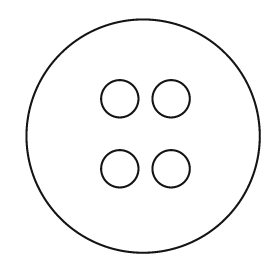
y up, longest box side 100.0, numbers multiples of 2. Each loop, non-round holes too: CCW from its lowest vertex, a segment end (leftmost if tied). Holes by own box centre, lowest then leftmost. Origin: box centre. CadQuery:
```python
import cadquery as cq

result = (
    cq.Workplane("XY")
    .moveTo(0.0, 0.0)
    .circle(50.0)
    .moveTo(-10.0, -14.0)
    .circle(8.0)
    .moveTo(12.0, -14.0)
    .circle(8.0)
    .moveTo(-10.0, 16.0)
    .circle(8.0)
    .moveTo(12.0, 16.0)
    .circle(8.0)
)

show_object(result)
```